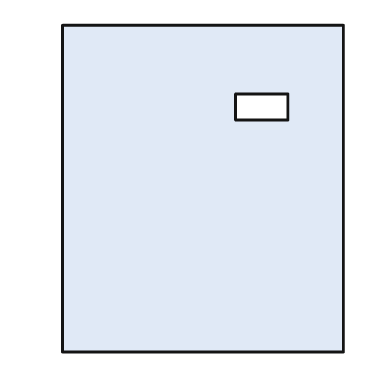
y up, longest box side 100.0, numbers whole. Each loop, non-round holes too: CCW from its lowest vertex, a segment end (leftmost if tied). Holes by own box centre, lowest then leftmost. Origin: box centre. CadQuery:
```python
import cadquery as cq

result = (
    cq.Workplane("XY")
    .moveTo(-43.0, -50.0)
    .lineTo(43.0, -50.0)
    .lineTo(43.0, 50.0)
    .lineTo(-43.0, 50.0)
    .close()
    .moveTo(10.0, 21.0)
    .lineTo(26.0, 21.0)
    .lineTo(26.0, 29.0)
    .lineTo(10.0, 29.0)
    .close()
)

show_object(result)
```